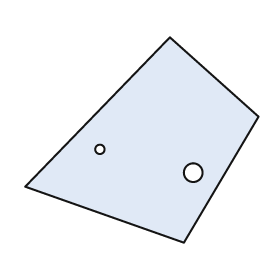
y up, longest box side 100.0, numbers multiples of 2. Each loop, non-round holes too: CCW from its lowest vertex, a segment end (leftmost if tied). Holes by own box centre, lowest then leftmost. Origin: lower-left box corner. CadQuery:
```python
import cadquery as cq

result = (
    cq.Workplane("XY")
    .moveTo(68.0, 0.0)
    .lineTo(100.0, 54.0)
    .lineTo(62.0, 88.0)
    .lineTo(0.0, 24.0)
    .close()
    .moveTo(72.0, 30.0)
    .circle(4.0)
    .moveTo(32.0, 40.0)
    .circle(2.0)
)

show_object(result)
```